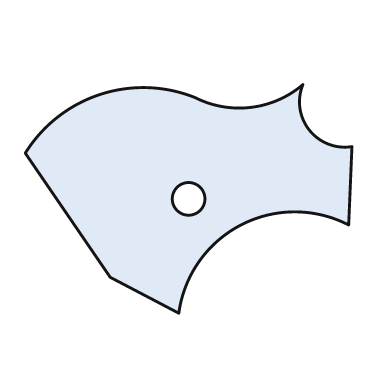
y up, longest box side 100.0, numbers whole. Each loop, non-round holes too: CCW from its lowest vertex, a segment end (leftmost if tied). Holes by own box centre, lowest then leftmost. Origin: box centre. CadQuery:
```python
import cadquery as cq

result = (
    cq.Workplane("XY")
    .moveTo(-3.0, -35.0)
    .threePointArc((16.0, -8.0), (49.0, -8.0))
    .lineTo(50.0, 16.0)
    .threePointArc((37.0, 21.0), (35.0, 35.0))
    .threePointArc((19.0, 28.0), (2.0, 31.0))
    .threePointArc((-27.0, 32.0), (-50.0, 14.0))
    .lineTo(-24.0, -24.0)
    .close()
    .moveTo(0.0, 0.0)
    .circle(5.0)
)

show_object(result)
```